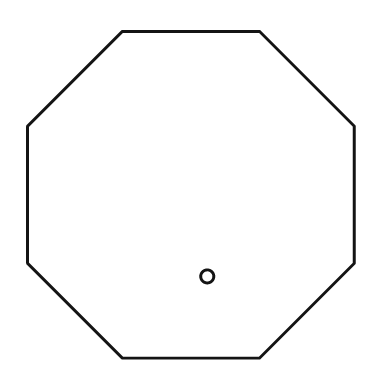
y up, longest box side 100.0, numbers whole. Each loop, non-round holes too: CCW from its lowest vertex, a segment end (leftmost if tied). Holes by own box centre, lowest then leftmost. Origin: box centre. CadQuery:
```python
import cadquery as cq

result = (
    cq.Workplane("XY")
    .moveTo(-21.0, -50.0)
    .lineTo(21.0, -50.0)
    .lineTo(50.0, -21.0)
    .lineTo(50.0, 21.0)
    .lineTo(21.0, 50.0)
    .lineTo(-21.0, 50.0)
    .lineTo(-50.0, 21.0)
    .lineTo(-50.0, -21.0)
    .close()
    .moveTo(5.0, -25.0)
    .circle(2.0)
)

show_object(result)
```